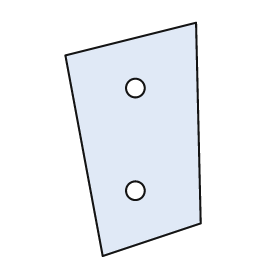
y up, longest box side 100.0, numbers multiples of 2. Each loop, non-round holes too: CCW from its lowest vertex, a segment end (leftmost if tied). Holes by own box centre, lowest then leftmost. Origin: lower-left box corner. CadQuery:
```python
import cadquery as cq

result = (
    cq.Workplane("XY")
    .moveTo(16.0, 0.0)
    .lineTo(58.0, 14.0)
    .lineTo(56.0, 100.0)
    .lineTo(0.0, 86.0)
    .close()
    .moveTo(30.0, 28.0)
    .circle(4.0)
    .moveTo(30.0, 72.0)
    .circle(4.0)
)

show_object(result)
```